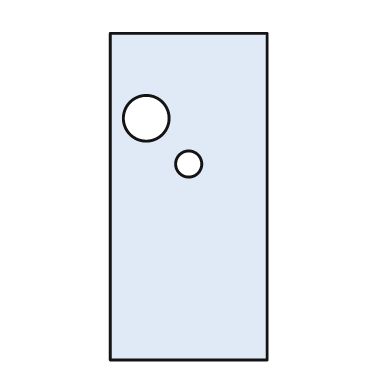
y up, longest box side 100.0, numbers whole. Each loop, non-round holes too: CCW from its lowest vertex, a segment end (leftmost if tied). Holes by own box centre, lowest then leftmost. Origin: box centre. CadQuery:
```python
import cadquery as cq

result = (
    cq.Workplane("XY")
    .moveTo(-24.0, -50.0)
    .lineTo(24.0, -50.0)
    .lineTo(24.0, 50.0)
    .lineTo(-24.0, 50.0)
    .close()
    .moveTo(0.0, 10.0)
    .circle(4.0)
    .moveTo(-13.0, 24.0)
    .circle(7.0)
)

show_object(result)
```